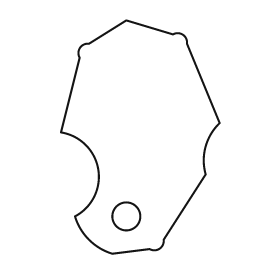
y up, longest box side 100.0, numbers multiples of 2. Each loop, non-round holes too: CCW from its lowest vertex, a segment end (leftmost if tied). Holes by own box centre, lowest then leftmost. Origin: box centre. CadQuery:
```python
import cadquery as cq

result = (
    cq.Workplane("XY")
    .moveTo(-12.0, -50.0)
    .lineTo(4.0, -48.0)
    .threePointArc((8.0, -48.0), (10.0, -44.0))
    .lineTo(28.0, -16.0)
    .threePointArc((28.0, -4.0), (34.0, 6.0))
    .lineTo(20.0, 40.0)
    .threePointArc((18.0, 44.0), (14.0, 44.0))
    .lineTo(-6.0, 50.0)
    .lineTo(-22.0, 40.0)
    .threePointArc((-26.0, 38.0), (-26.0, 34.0))
    .lineTo(-34.0, 2.0)
    .threePointArc((-18.0, -14.0), (-28.0, -34.0))
    .threePointArc((-22.0, -44.0), (-12.0, -50.0))
    .close()
    .moveTo(-6.0, -34.0)
    .circle(6.0)
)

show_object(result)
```